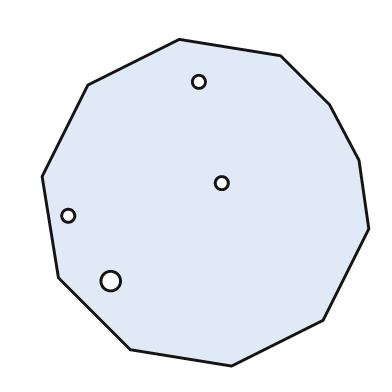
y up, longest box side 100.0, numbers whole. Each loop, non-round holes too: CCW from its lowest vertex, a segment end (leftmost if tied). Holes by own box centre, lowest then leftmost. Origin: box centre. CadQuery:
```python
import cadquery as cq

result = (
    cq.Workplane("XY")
    .moveTo(8.0, -50.0)
    .lineTo(36.0, -36.0)
    .lineTo(50.0, -8.0)
    .lineTo(47.0, 13.0)
    .lineTo(38.0, 30.0)
    .lineTo(23.0, 45.0)
    .lineTo(-8.0, 50.0)
    .lineTo(-36.0, 36.0)
    .lineTo(-50.0, 8.0)
    .lineTo(-45.0, -23.0)
    .lineTo(-23.0, -45.0)
    .close()
    .moveTo(-29.0, -24.0)
    .circle(3.0)
    .moveTo(-42.0, -4.0)
    .circle(2.0)
    .moveTo(5.0, 6.0)
    .circle(2.0)
    .moveTo(-2.0, 37.0)
    .circle(2.0)
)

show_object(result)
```